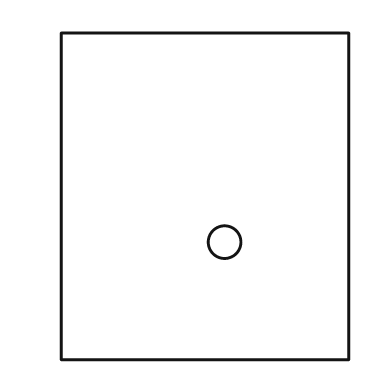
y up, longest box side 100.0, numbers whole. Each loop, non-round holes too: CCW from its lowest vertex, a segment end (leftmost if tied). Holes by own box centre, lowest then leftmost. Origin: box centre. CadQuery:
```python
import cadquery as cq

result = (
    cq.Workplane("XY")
    .moveTo(-44.0, -50.0)
    .lineTo(44.0, -50.0)
    .lineTo(44.0, 50.0)
    .lineTo(-44.0, 50.0)
    .close()
    .moveTo(6.0, -14.0)
    .circle(5.0)
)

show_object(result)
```